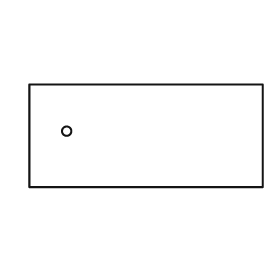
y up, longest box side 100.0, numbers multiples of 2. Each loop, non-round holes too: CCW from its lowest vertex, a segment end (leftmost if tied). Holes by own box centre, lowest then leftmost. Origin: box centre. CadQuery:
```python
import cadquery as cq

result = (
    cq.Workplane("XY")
    .moveTo(-50.0, -22.0)
    .lineTo(50.0, -22.0)
    .lineTo(50.0, 22.0)
    .lineTo(-50.0, 22.0)
    .close()
    .moveTo(-34.0, 2.0)
    .circle(2.0)
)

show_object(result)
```